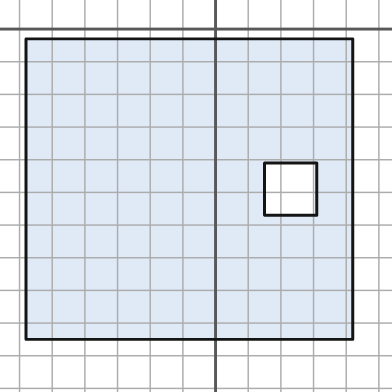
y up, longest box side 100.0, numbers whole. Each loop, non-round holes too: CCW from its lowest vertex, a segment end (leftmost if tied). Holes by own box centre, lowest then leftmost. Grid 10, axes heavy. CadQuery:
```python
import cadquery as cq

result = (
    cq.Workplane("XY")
    .moveTo(-58.0, -95.0)
    .lineTo(42.0, -95.0)
    .lineTo(42.0, -3.0)
    .lineTo(-58.0, -3.0)
    .close()
    .moveTo(15.0, -57.0)
    .lineTo(31.0, -57.0)
    .lineTo(31.0, -41.0)
    .lineTo(15.0, -41.0)
    .close()
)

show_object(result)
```